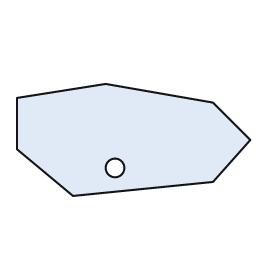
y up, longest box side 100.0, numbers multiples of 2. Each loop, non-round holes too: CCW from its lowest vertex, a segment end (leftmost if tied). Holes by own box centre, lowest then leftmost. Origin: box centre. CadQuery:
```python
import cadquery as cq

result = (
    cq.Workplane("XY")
    .moveTo(-26.0, -24.0)
    .lineTo(34.0, -18.0)
    .lineTo(50.0, 0.0)
    .lineTo(34.0, 16.0)
    .lineTo(-12.0, 24.0)
    .lineTo(-50.0, 18.0)
    .lineTo(-50.0, -4.0)
    .close()
    .moveTo(-8.0, -12.0)
    .circle(4.0)
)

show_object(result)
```